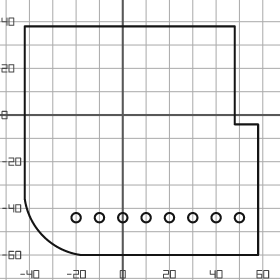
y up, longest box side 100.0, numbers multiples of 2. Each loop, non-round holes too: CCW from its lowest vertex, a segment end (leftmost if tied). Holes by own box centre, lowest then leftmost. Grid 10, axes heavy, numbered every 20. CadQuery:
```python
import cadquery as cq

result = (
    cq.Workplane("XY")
    .moveTo(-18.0, -60.0)
    .lineTo(58.0, -60.0)
    .lineTo(58.0, -4.0)
    .lineTo(48.0, -4.0)
    .lineTo(48.0, 38.0)
    .lineTo(-42.0, 38.0)
    .lineTo(-42.0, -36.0)
    .threePointArc((-34.0, -52.0), (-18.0, -60.0))
    .close()
    .moveTo(-20.0, -44.0)
    .circle(2.0)
    .moveTo(-10.0, -44.0)
    .circle(2.0)
    .moveTo(0.0, -44.0)
    .circle(2.0)
    .moveTo(10.0, -44.0)
    .circle(2.0)
    .moveTo(20.0, -44.0)
    .circle(2.0)
    .moveTo(30.0, -44.0)
    .circle(2.0)
    .moveTo(40.0, -44.0)
    .circle(2.0)
    .moveTo(50.0, -44.0)
    .circle(2.0)
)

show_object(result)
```